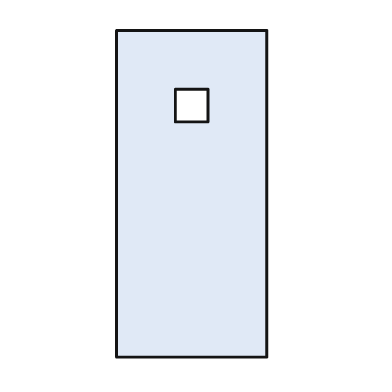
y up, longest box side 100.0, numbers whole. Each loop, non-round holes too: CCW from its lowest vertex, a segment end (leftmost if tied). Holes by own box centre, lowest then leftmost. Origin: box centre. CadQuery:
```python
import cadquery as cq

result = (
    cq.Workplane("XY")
    .moveTo(-23.0, -50.0)
    .lineTo(23.0, -50.0)
    .lineTo(23.0, 50.0)
    .lineTo(-23.0, 50.0)
    .close()
    .moveTo(-5.0, 22.0)
    .lineTo(5.0, 22.0)
    .lineTo(5.0, 32.0)
    .lineTo(-5.0, 32.0)
    .close()
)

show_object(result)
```